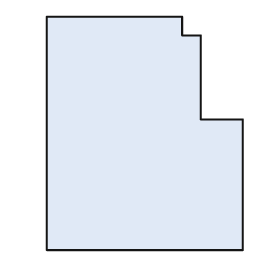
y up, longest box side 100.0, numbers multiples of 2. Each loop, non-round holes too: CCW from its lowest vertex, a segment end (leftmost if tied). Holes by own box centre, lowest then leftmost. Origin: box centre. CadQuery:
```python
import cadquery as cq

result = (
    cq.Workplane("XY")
    .moveTo(-42.0, -50.0)
    .lineTo(42.0, -50.0)
    .lineTo(42.0, 6.0)
    .lineTo(24.0, 6.0)
    .lineTo(24.0, 42.0)
    .lineTo(16.0, 42.0)
    .lineTo(16.0, 50.0)
    .lineTo(-42.0, 50.0)
    .close()
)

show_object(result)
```